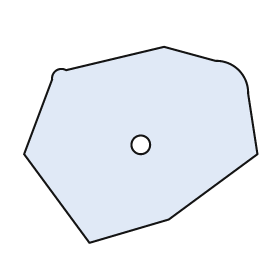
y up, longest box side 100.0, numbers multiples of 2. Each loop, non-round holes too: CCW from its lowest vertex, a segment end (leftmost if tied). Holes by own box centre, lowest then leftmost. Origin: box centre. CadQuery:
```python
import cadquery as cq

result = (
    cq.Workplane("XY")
    .moveTo(-22.0, -42.0)
    .lineTo(12.0, -32.0)
    .lineTo(50.0, -4.0)
    .lineTo(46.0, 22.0)
    .threePointArc((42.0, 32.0), (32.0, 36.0))
    .lineTo(10.0, 42.0)
    .lineTo(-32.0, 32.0)
    .threePointArc((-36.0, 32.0), (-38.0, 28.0))
    .lineTo(-50.0, -4.0)
    .close()
    .moveTo(0.0, 0.0)
    .circle(4.0)
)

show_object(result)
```